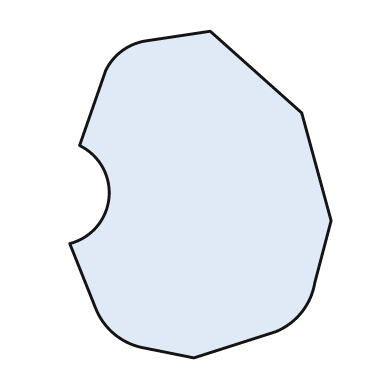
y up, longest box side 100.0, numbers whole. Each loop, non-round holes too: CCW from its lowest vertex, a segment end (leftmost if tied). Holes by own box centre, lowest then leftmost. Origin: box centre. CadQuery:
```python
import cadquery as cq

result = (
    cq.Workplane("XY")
    .moveTo(-2.0, -50.0)
    .lineTo(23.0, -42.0)
    .threePointArc((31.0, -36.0), (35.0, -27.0))
    .lineTo(40.0, -8.0)
    .lineTo(31.0, 25.0)
    .lineTo(3.0, 50.0)
    .lineTo(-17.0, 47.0)
    .threePointArc((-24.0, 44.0), (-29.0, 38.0))
    .lineTo(-37.0, 15.0)
    .threePointArc((-28.0, -1.0), (-40.0, -15.0))
    .lineTo(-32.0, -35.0)
    .threePointArc((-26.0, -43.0), (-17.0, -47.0))
    .close()
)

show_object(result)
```